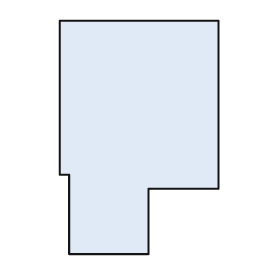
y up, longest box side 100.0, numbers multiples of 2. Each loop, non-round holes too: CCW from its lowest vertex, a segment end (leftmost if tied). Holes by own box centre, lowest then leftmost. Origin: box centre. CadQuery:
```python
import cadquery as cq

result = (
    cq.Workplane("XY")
    .moveTo(-30.0, -50.0)
    .lineTo(4.0, -50.0)
    .lineTo(4.0, -22.0)
    .lineTo(34.0, -22.0)
    .lineTo(34.0, 50.0)
    .lineTo(-34.0, 50.0)
    .lineTo(-34.0, -16.0)
    .lineTo(-30.0, -16.0)
    .close()
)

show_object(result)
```